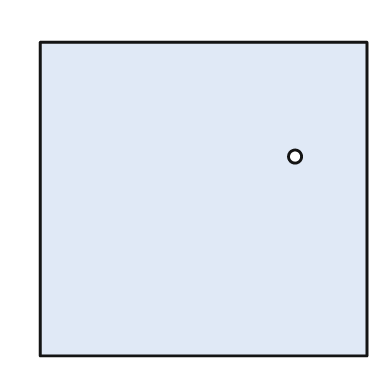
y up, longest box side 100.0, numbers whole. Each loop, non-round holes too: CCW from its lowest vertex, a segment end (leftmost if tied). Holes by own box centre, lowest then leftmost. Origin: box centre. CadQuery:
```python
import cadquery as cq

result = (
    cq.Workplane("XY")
    .moveTo(-50.0, -48.0)
    .lineTo(50.0, -48.0)
    .lineTo(50.0, 48.0)
    .lineTo(-50.0, 48.0)
    .close()
    .moveTo(28.0, 13.0)
    .circle(2.0)
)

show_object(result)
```